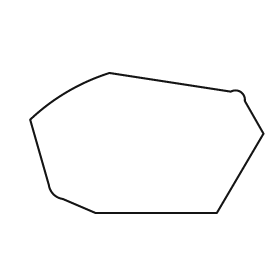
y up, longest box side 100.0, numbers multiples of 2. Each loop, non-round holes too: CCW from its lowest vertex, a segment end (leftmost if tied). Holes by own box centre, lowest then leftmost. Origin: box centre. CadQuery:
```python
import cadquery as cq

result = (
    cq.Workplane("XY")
    .moveTo(-22.0, -30.0)
    .lineTo(30.0, -30.0)
    .lineTo(50.0, 4.0)
    .lineTo(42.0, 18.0)
    .threePointArc((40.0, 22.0), (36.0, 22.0))
    .lineTo(-16.0, 30.0)
    .threePointArc((-34.0, 22.0), (-50.0, 10.0))
    .lineTo(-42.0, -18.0)
    .threePointArc((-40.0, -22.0), (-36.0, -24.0))
    .close()
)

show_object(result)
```